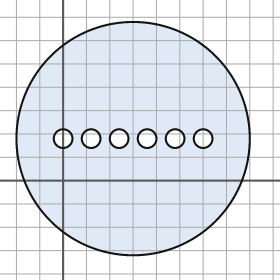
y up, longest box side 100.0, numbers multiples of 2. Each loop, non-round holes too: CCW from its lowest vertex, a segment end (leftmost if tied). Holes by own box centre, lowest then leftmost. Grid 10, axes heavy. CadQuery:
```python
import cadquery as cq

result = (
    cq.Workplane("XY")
    .moveTo(30.0, 18.0)
    .circle(50.0)
    .moveTo(0.0, 18.0)
    .circle(4.0)
    .moveTo(12.0, 18.0)
    .circle(4.0)
    .moveTo(24.0, 18.0)
    .circle(4.0)
    .moveTo(36.0, 18.0)
    .circle(4.0)
    .moveTo(48.0, 18.0)
    .circle(4.0)
    .moveTo(60.0, 18.0)
    .circle(4.0)
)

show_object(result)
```